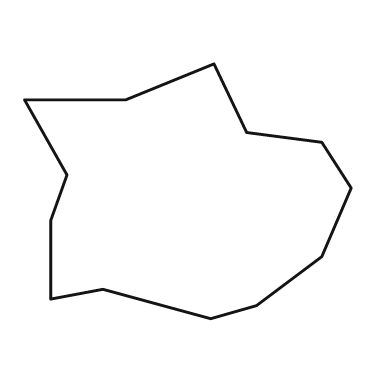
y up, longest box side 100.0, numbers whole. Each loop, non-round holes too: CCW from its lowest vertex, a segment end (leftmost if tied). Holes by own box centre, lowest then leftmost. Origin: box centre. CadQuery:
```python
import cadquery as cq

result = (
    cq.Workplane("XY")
    .moveTo(7.0, -39.0)
    .lineTo(21.0, -35.0)
    .lineTo(41.0, -20.0)
    .lineTo(50.0, 1.0)
    .lineTo(41.0, 15.0)
    .lineTo(18.0, 18.0)
    .lineTo(8.0, 39.0)
    .lineTo(-19.0, 28.0)
    .lineTo(-50.0, 28.0)
    .lineTo(-37.0, 5.0)
    .lineTo(-42.0, -9.0)
    .lineTo(-42.0, -33.0)
    .lineTo(-26.0, -30.0)
    .close()
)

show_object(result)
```